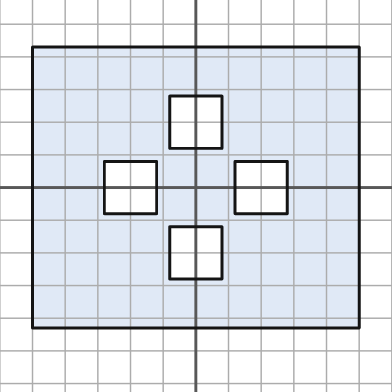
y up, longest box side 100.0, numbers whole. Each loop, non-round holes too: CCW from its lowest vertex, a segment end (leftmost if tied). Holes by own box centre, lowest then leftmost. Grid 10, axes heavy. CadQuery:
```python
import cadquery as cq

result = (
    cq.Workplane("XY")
    .moveTo(-50.0, -43.0)
    .lineTo(50.0, -43.0)
    .lineTo(50.0, 43.0)
    .lineTo(-50.0, 43.0)
    .close()
    .moveTo(-8.0, -28.0)
    .lineTo(8.0, -28.0)
    .lineTo(8.0, -12.0)
    .lineTo(-8.0, -12.0)
    .close()
    .moveTo(-28.0, -8.0)
    .lineTo(-12.0, -8.0)
    .lineTo(-12.0, 8.0)
    .lineTo(-28.0, 8.0)
    .close()
    .moveTo(12.0, -8.0)
    .lineTo(28.0, -8.0)
    .lineTo(28.0, 8.0)
    .lineTo(12.0, 8.0)
    .close()
    .moveTo(-8.0, 12.0)
    .lineTo(8.0, 12.0)
    .lineTo(8.0, 28.0)
    .lineTo(-8.0, 28.0)
    .close()
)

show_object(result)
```